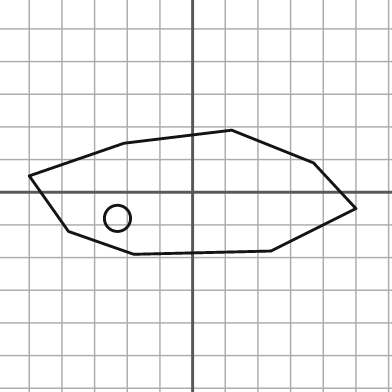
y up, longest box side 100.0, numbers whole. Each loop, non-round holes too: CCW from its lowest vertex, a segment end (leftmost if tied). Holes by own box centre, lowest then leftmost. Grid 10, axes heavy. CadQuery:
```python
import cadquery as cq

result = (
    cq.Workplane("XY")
    .moveTo(-18.0, -19.0)
    .lineTo(24.0, -18.0)
    .lineTo(50.0, -5.0)
    .lineTo(37.0, 9.0)
    .lineTo(12.0, 19.0)
    .lineTo(-21.0, 15.0)
    .lineTo(-50.0, 5.0)
    .lineTo(-38.0, -12.0)
    .close()
    .moveTo(-23.0, -8.0)
    .circle(4.0)
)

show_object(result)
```